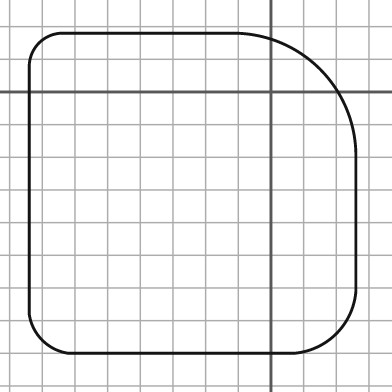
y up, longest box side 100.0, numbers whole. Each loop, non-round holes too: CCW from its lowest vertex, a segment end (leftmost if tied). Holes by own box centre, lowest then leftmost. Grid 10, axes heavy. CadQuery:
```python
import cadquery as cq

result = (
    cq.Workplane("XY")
    .moveTo(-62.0, -80.0)
    .lineTo(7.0, -80.0)
    .threePointArc((20.0, -74.0), (26.0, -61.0))
    .lineTo(26.0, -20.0)
    .threePointArc((15.0, 7.0), (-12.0, 18.0))
    .lineTo(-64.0, 18.0)
    .threePointArc((-71.0, 15.0), (-74.0, 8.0))
    .lineTo(-74.0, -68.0)
    .threePointArc((-70.0, -76.0), (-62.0, -80.0))
    .close()
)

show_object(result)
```